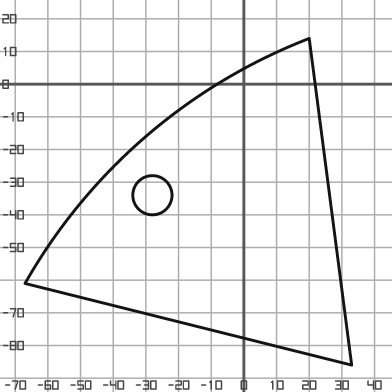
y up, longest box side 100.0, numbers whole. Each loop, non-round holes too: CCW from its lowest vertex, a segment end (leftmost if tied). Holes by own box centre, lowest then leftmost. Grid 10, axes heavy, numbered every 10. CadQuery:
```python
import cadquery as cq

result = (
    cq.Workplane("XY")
    .moveTo(33.0, -86.0)
    .lineTo(20.0, 14.0)
    .threePointArc((-30.0, -16.0), (-67.0, -61.0))
    .close()
    .moveTo(-28.0, -34.0)
    .circle(6.0)
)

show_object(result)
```